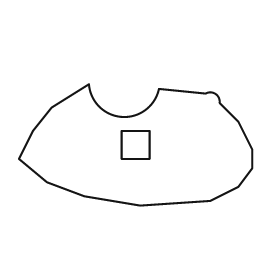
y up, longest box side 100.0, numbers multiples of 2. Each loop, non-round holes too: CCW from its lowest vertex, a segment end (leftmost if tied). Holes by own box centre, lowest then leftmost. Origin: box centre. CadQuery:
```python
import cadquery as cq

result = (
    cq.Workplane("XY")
    .moveTo(2.0, -26.0)
    .lineTo(32.0, -24.0)
    .lineTo(44.0, -18.0)
    .lineTo(50.0, -10.0)
    .lineTo(50.0, -2.0)
    .lineTo(44.0, 10.0)
    .lineTo(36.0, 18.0)
    .threePointArc((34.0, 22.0), (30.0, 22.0))
    .lineTo(10.0, 24.0)
    .threePointArc((-6.0, 12.0), (-20.0, 26.0))
    .lineTo(-36.0, 16.0)
    .lineTo(-44.0, 6.0)
    .lineTo(-50.0, -6.0)
    .lineTo(-38.0, -16.0)
    .lineTo(-22.0, -22.0)
    .close()
    .moveTo(-6.0, -6.0)
    .lineTo(6.0, -6.0)
    .lineTo(6.0, 6.0)
    .lineTo(-6.0, 6.0)
    .close()
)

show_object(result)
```